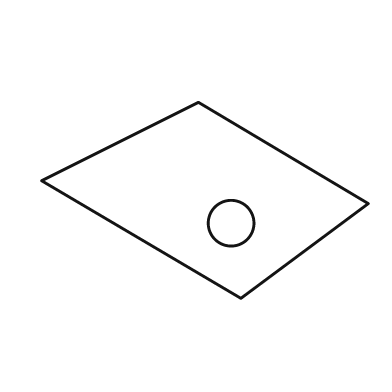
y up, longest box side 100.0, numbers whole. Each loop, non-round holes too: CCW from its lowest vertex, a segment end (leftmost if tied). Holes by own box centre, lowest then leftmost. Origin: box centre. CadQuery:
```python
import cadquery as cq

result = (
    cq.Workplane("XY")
    .moveTo(11.0, -30.0)
    .lineTo(50.0, -1.0)
    .lineTo(-2.0, 30.0)
    .lineTo(-50.0, 6.0)
    .close()
    .moveTo(8.0, -7.0)
    .circle(7.0)
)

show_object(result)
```